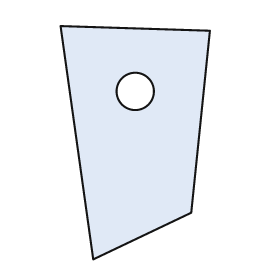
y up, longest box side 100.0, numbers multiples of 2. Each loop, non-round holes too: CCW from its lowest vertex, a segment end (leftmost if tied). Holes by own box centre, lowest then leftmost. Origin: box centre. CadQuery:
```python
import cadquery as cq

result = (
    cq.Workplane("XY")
    .moveTo(-18.0, -50.0)
    .lineTo(24.0, -30.0)
    .lineTo(32.0, 48.0)
    .lineTo(-32.0, 50.0)
    .close()
    .moveTo(0.0, 22.0)
    .circle(8.0)
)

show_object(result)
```